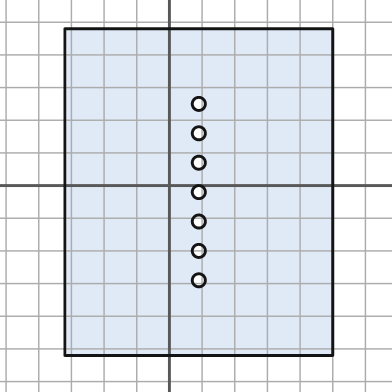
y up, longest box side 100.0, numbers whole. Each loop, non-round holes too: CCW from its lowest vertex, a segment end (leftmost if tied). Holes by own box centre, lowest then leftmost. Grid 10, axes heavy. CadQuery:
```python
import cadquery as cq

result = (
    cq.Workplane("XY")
    .moveTo(-32.0, -52.0)
    .lineTo(50.0, -52.0)
    .lineTo(50.0, 48.0)
    .lineTo(-32.0, 48.0)
    .close()
    .moveTo(9.0, -29.0)
    .circle(2.0)
    .moveTo(9.0, -20.0)
    .circle(2.0)
    .moveTo(9.0, -11.0)
    .circle(2.0)
    .moveTo(9.0, -2.0)
    .circle(2.0)
    .moveTo(9.0, 7.0)
    .circle(2.0)
    .moveTo(9.0, 16.0)
    .circle(2.0)
    .moveTo(9.0, 25.0)
    .circle(2.0)
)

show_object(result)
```